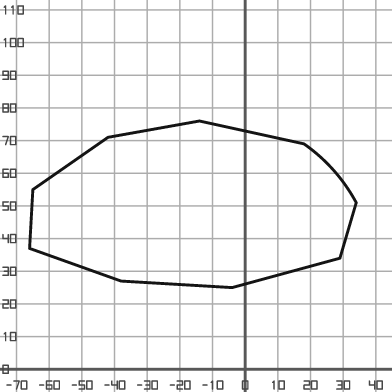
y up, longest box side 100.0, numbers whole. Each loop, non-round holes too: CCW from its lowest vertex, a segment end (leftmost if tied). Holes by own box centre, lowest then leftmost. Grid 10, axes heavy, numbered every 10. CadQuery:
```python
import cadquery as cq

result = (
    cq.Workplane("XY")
    .moveTo(-4.0, 25.0)
    .lineTo(29.0, 34.0)
    .lineTo(34.0, 51.0)
    .threePointArc((27.0, 61.0), (18.0, 69.0))
    .lineTo(-14.0, 76.0)
    .lineTo(-42.0, 71.0)
    .lineTo(-65.0, 55.0)
    .lineTo(-66.0, 37.0)
    .lineTo(-38.0, 27.0)
    .close()
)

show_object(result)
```